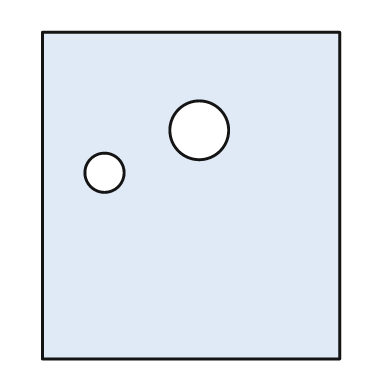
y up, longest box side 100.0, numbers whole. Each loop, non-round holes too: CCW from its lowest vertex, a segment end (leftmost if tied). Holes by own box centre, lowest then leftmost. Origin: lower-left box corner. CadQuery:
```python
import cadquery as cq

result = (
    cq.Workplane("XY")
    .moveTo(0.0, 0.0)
    .lineTo(91.0, 0.0)
    .lineTo(91.0, 100.0)
    .lineTo(0.0, 100.0)
    .close()
    .moveTo(19.0, 57.0)
    .circle(6.0)
    .moveTo(48.0, 70.0)
    .circle(9.0)
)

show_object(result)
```